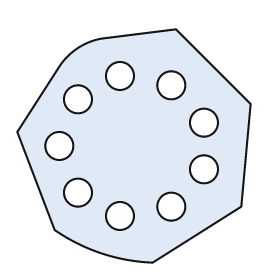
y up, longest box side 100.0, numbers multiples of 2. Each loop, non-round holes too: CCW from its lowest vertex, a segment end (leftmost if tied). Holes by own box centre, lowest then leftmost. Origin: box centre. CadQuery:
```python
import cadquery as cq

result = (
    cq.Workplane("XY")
    .moveTo(8.0, -50.0)
    .lineTo(46.0, -26.0)
    .lineTo(50.0, 18.0)
    .lineTo(18.0, 50.0)
    .lineTo(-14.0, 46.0)
    .threePointArc((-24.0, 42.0), (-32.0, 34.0))
    .lineTo(-50.0, 6.0)
    .lineTo(-34.0, -36.0)
    .threePointArc((-14.0, -46.0), (8.0, -50.0))
    .close()
    .moveTo(-6.0, -30.0)
    .circle(6.0)
    .moveTo(16.0, -26.0)
    .circle(6.0)
    .moveTo(-24.0, -20.0)
    .circle(6.0)
    .moveTo(30.0, -10.0)
    .circle(6.0)
    .moveTo(-32.0, 0.0)
    .circle(6.0)
    .moveTo(30.0, 10.0)
    .circle(6.0)
    .moveTo(-24.0, 20.0)
    .circle(6.0)
    .moveTo(16.0, 26.0)
    .circle(6.0)
    .moveTo(-6.0, 30.0)
    .circle(6.0)
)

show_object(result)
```